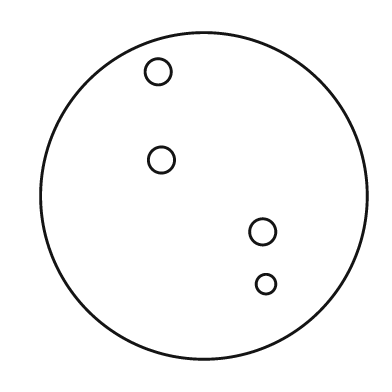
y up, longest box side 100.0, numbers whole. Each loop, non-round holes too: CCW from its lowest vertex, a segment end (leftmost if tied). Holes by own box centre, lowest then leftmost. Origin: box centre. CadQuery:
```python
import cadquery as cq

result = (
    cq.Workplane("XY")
    .moveTo(0.0, 0.0)
    .circle(50.0)
    .moveTo(19.0, -27.0)
    .circle(3.0)
    .moveTo(18.0, -11.0)
    .circle(4.0)
    .moveTo(-13.0, 11.0)
    .circle(4.0)
    .moveTo(-14.0, 38.0)
    .circle(4.0)
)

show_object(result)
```